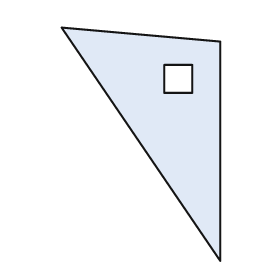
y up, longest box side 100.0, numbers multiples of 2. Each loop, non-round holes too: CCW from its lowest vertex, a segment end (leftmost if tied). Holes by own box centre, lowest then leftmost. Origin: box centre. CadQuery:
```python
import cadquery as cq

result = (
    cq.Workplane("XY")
    .moveTo(34.0, -50.0)
    .lineTo(34.0, 44.0)
    .lineTo(-34.0, 50.0)
    .close()
    .moveTo(10.0, 22.0)
    .lineTo(22.0, 22.0)
    .lineTo(22.0, 34.0)
    .lineTo(10.0, 34.0)
    .close()
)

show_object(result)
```